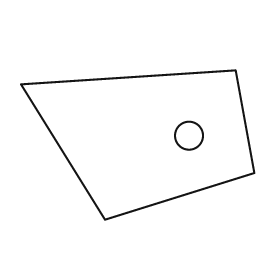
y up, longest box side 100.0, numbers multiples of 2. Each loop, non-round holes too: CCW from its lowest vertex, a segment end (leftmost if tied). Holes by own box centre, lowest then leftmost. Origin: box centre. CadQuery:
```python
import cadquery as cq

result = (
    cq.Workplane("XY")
    .moveTo(-14.0, -32.0)
    .lineTo(50.0, -12.0)
    .lineTo(42.0, 32.0)
    .lineTo(-50.0, 26.0)
    .close()
    .moveTo(22.0, 4.0)
    .circle(6.0)
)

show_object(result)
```